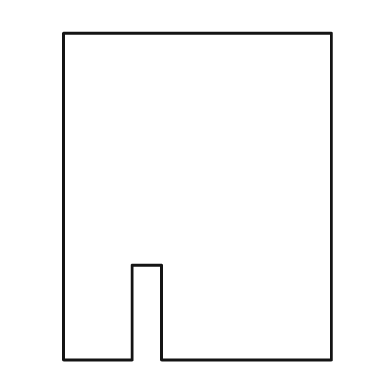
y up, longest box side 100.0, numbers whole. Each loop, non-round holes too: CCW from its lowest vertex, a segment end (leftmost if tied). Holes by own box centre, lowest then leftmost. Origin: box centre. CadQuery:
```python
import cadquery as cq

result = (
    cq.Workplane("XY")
    .moveTo(-41.0, -50.0)
    .lineTo(-20.0, -50.0)
    .lineTo(-20.0, -21.0)
    .lineTo(-11.0, -21.0)
    .lineTo(-11.0, -50.0)
    .lineTo(41.0, -50.0)
    .lineTo(41.0, 50.0)
    .lineTo(-41.0, 50.0)
    .close()
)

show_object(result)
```